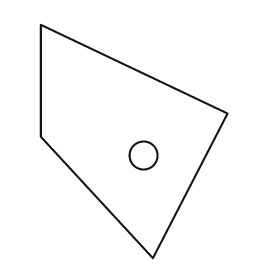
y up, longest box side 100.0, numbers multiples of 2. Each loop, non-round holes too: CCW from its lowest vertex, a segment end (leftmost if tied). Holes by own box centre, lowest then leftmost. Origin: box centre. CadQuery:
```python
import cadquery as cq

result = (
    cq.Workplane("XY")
    .moveTo(8.0, -50.0)
    .lineTo(40.0, 12.0)
    .lineTo(-40.0, 50.0)
    .lineTo(-40.0, 2.0)
    .close()
    .moveTo(4.0, -6.0)
    .circle(6.0)
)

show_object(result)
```